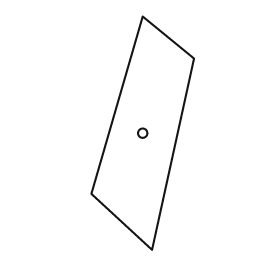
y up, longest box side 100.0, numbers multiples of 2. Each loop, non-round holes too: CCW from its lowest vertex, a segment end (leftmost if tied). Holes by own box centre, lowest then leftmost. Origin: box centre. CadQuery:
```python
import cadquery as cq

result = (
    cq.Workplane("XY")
    .moveTo(4.0, -50.0)
    .lineTo(22.0, 32.0)
    .lineTo(0.0, 50.0)
    .lineTo(-22.0, -26.0)
    .close()
    .moveTo(0.0, 0.0)
    .circle(2.0)
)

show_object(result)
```